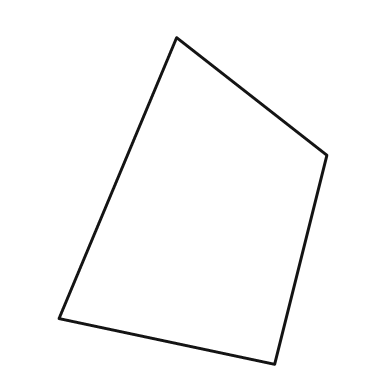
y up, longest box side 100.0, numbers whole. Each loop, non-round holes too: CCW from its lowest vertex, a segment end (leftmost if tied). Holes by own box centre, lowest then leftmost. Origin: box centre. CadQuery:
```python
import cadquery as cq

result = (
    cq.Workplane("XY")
    .moveTo(25.0, -50.0)
    .lineTo(41.0, 14.0)
    .lineTo(-5.0, 50.0)
    .lineTo(-41.0, -36.0)
    .close()
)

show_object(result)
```